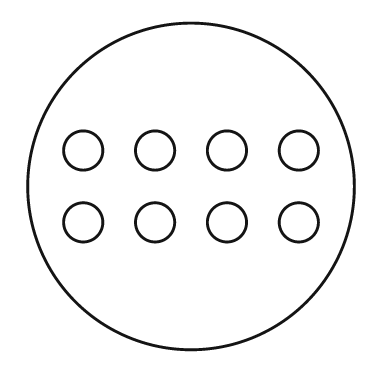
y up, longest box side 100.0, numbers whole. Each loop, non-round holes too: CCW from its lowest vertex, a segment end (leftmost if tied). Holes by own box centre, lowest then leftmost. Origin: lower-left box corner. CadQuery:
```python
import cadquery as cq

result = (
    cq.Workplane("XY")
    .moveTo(50.0, 50.0)
    .circle(50.0)
    .moveTo(17.0, 39.0)
    .circle(6.0)
    .moveTo(39.0, 39.0)
    .circle(6.0)
    .moveTo(61.0, 39.0)
    .circle(6.0)
    .moveTo(83.0, 39.0)
    .circle(6.0)
    .moveTo(17.0, 61.0)
    .circle(6.0)
    .moveTo(39.0, 61.0)
    .circle(6.0)
    .moveTo(61.0, 61.0)
    .circle(6.0)
    .moveTo(83.0, 61.0)
    .circle(6.0)
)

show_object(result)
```